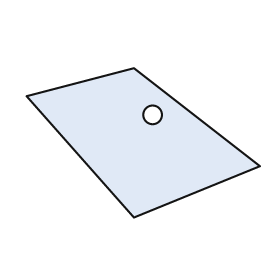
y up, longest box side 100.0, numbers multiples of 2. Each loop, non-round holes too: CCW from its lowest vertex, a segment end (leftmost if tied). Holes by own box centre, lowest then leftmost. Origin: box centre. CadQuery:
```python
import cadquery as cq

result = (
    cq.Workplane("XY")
    .moveTo(-4.0, -32.0)
    .lineTo(50.0, -10.0)
    .lineTo(-4.0, 32.0)
    .lineTo(-50.0, 20.0)
    .close()
    .moveTo(4.0, 12.0)
    .circle(4.0)
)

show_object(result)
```